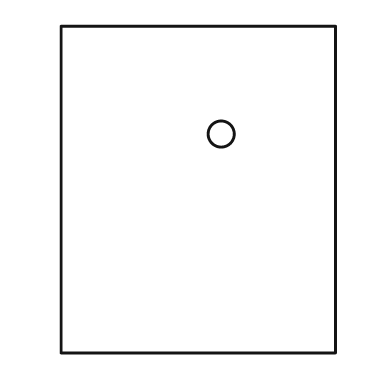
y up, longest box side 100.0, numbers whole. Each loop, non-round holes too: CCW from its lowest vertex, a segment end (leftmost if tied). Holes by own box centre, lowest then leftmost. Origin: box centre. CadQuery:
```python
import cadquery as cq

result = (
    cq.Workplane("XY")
    .moveTo(-42.0, -50.0)
    .lineTo(42.0, -50.0)
    .lineTo(42.0, 50.0)
    .lineTo(-42.0, 50.0)
    .close()
    .moveTo(7.0, 17.0)
    .circle(4.0)
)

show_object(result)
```